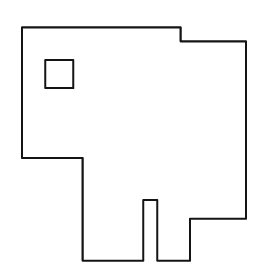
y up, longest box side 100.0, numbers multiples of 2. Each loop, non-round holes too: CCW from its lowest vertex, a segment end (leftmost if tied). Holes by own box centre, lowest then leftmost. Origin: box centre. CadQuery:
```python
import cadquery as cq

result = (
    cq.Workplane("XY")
    .moveTo(-22.0, -50.0)
    .lineTo(4.0, -50.0)
    .lineTo(4.0, -24.0)
    .lineTo(10.0, -24.0)
    .lineTo(10.0, -50.0)
    .lineTo(24.0, -50.0)
    .lineTo(24.0, -32.0)
    .lineTo(48.0, -32.0)
    .lineTo(48.0, 44.0)
    .lineTo(20.0, 44.0)
    .lineTo(20.0, 50.0)
    .lineTo(-48.0, 50.0)
    .lineTo(-48.0, -6.0)
    .lineTo(-22.0, -6.0)
    .close()
    .moveTo(-38.0, 24.0)
    .lineTo(-26.0, 24.0)
    .lineTo(-26.0, 36.0)
    .lineTo(-38.0, 36.0)
    .close()
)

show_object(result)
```